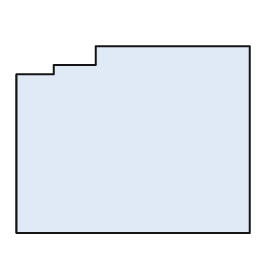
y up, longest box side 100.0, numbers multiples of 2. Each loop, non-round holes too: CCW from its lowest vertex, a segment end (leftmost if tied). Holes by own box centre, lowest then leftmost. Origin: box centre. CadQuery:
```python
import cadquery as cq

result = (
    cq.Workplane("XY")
    .moveTo(-50.0, -40.0)
    .lineTo(50.0, -40.0)
    .lineTo(50.0, 40.0)
    .lineTo(-16.0, 40.0)
    .lineTo(-16.0, 32.0)
    .lineTo(-34.0, 32.0)
    .lineTo(-34.0, 28.0)
    .lineTo(-50.0, 28.0)
    .close()
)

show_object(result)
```